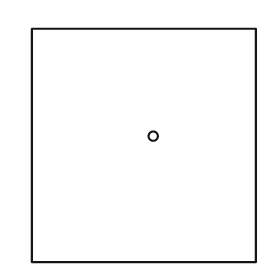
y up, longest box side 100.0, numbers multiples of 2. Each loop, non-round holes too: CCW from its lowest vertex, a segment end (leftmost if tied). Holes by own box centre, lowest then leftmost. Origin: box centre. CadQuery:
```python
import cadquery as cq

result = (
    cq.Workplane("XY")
    .moveTo(-48.0, -50.0)
    .lineTo(48.0, -50.0)
    .lineTo(48.0, 50.0)
    .lineTo(-48.0, 50.0)
    .close()
    .moveTo(4.0, 4.0)
    .circle(2.0)
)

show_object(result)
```